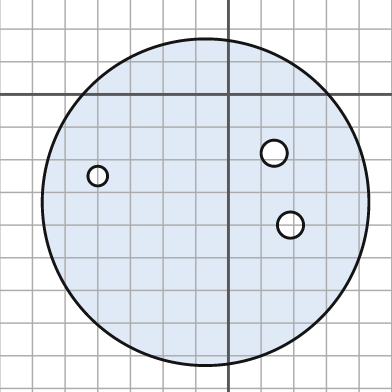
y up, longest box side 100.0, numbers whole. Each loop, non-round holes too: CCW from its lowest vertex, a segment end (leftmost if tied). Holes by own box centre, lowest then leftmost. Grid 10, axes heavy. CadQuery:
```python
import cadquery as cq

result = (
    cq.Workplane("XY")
    .moveTo(-7.0, -33.0)
    .circle(50.0)
    .moveTo(19.0, -40.0)
    .circle(4.0)
    .moveTo(-40.0, -25.0)
    .circle(3.0)
    .moveTo(14.0, -18.0)
    .circle(4.0)
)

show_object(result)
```